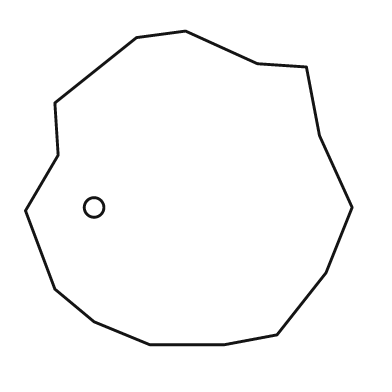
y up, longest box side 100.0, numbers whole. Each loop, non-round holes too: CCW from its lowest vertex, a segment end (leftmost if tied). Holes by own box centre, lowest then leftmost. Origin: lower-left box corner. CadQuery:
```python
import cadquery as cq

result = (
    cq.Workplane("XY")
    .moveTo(38.0, 0.0)
    .lineTo(61.0, 0.0)
    .lineTo(77.0, 3.0)
    .lineTo(92.0, 22.0)
    .lineTo(100.0, 42.0)
    .lineTo(90.0, 64.0)
    .lineTo(86.0, 85.0)
    .lineTo(71.0, 86.0)
    .lineTo(49.0, 96.0)
    .lineTo(34.0, 94.0)
    .lineTo(9.0, 74.0)
    .lineTo(10.0, 58.0)
    .lineTo(0.0, 41.0)
    .lineTo(9.0, 17.0)
    .lineTo(21.0, 7.0)
    .close()
    .moveTo(21.0, 42.0)
    .circle(3.0)
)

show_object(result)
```